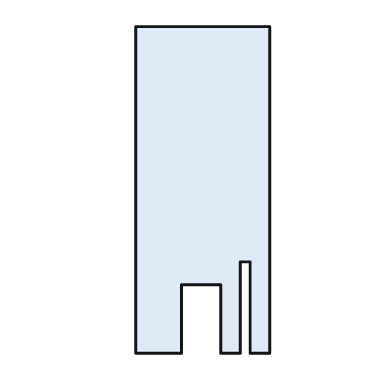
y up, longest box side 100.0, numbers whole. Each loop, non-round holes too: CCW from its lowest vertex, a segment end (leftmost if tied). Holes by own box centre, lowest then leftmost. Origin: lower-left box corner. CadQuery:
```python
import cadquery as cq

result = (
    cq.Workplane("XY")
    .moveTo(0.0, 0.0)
    .lineTo(14.0, 0.0)
    .lineTo(14.0, 21.0)
    .lineTo(26.0, 21.0)
    .lineTo(26.0, 0.0)
    .lineTo(32.0, 0.0)
    .lineTo(32.0, 28.0)
    .lineTo(35.0, 28.0)
    .lineTo(35.0, 0.0)
    .lineTo(41.0, 0.0)
    .lineTo(41.0, 100.0)
    .lineTo(0.0, 100.0)
    .close()
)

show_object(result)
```